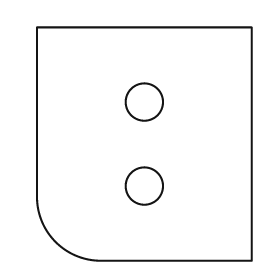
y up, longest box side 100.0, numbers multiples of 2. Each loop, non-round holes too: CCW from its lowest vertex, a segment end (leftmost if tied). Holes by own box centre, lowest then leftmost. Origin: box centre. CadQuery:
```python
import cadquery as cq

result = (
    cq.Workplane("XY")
    .moveTo(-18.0, -50.0)
    .lineTo(46.0, -50.0)
    .lineTo(46.0, 50.0)
    .lineTo(-46.0, 50.0)
    .lineTo(-46.0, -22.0)
    .threePointArc((-38.0, -42.0), (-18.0, -50.0))
    .close()
    .moveTo(0.0, -18.0)
    .circle(8.0)
    .moveTo(0.0, 18.0)
    .circle(8.0)
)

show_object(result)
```